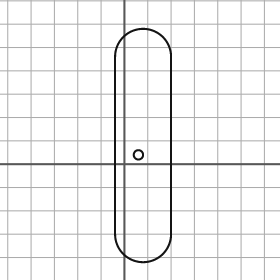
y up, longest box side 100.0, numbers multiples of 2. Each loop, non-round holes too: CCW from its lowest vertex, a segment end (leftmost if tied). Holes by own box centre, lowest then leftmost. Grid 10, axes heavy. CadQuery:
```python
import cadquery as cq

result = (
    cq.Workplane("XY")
    .moveTo(-4.0, -30.0)
    .threePointArc((8.0, -42.0), (20.0, -30.0))
    .lineTo(20.0, 46.0)
    .threePointArc((8.0, 58.0), (-4.0, 46.0))
    .close()
    .moveTo(6.0, 4.0)
    .circle(2.0)
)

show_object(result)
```